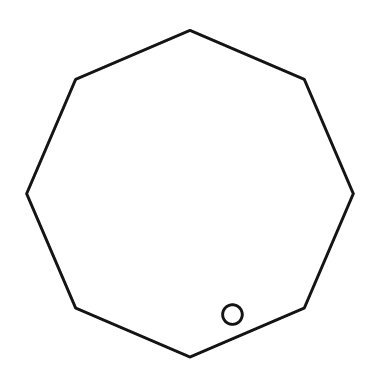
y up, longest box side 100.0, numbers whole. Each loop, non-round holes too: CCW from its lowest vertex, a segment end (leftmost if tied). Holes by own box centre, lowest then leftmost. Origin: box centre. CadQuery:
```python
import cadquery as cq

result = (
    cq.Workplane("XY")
    .moveTo(0.0, -50.0)
    .lineTo(35.0, -35.0)
    .lineTo(50.0, 0.0)
    .lineTo(35.0, 35.0)
    .lineTo(0.0, 50.0)
    .lineTo(-35.0, 35.0)
    .lineTo(-50.0, 0.0)
    .lineTo(-35.0, -35.0)
    .close()
    .moveTo(13.0, -37.0)
    .circle(3.0)
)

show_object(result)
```